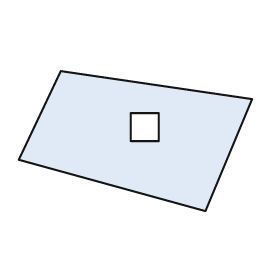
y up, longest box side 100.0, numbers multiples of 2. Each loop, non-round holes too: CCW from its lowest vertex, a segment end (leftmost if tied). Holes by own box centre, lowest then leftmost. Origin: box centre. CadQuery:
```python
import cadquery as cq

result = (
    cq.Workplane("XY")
    .moveTo(30.0, -30.0)
    .lineTo(50.0, 18.0)
    .lineTo(-32.0, 30.0)
    .lineTo(-50.0, -8.0)
    .close()
    .moveTo(-2.0, 0.0)
    .lineTo(10.0, 0.0)
    .lineTo(10.0, 12.0)
    .lineTo(-2.0, 12.0)
    .close()
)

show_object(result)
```